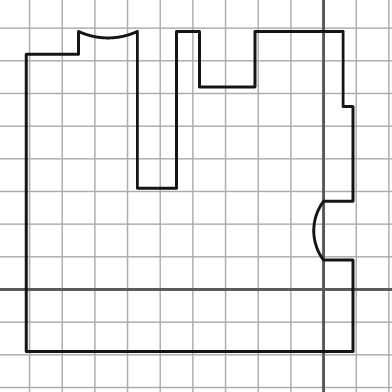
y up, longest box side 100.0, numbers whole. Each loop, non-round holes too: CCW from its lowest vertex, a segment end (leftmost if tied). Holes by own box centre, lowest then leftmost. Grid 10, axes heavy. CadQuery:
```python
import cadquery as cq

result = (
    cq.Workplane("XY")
    .moveTo(-91.0, -19.0)
    .lineTo(9.0, -19.0)
    .lineTo(9.0, 9.0)
    .lineTo(0.0, 9.0)
    .threePointArc((-3.0, 18.0), (0.0, 27.0))
    .lineTo(9.0, 27.0)
    .lineTo(9.0, 56.0)
    .lineTo(6.0, 56.0)
    .lineTo(6.0, 79.0)
    .lineTo(-21.0, 79.0)
    .lineTo(-21.0, 62.0)
    .lineTo(-38.0, 62.0)
    .lineTo(-38.0, 79.0)
    .lineTo(-45.0, 79.0)
    .lineTo(-45.0, 31.0)
    .lineTo(-57.0, 31.0)
    .lineTo(-57.0, 79.0)
    .threePointArc((-66.0, 77.0), (-75.0, 79.0))
    .lineTo(-75.0, 72.0)
    .lineTo(-91.0, 72.0)
    .close()
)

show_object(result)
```